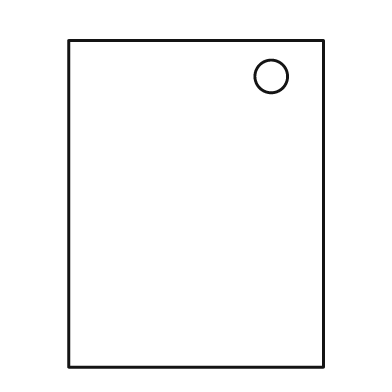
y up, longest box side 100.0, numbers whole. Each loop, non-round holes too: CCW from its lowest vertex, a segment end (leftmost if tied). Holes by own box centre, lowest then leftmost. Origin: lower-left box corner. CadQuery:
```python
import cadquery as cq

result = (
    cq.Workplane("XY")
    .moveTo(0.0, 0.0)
    .lineTo(78.0, 0.0)
    .lineTo(78.0, 100.0)
    .lineTo(0.0, 100.0)
    .close()
    .moveTo(62.0, 89.0)
    .circle(5.0)
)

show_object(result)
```